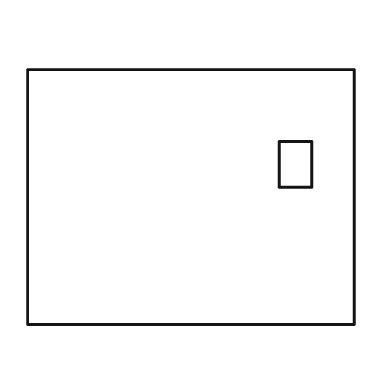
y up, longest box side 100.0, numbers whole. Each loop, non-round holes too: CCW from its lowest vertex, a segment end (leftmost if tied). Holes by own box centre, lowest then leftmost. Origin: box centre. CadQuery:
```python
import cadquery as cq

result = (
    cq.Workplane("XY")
    .moveTo(-50.0, -39.0)
    .lineTo(50.0, -39.0)
    .lineTo(50.0, 39.0)
    .lineTo(-50.0, 39.0)
    .close()
    .moveTo(27.0, 3.0)
    .lineTo(37.0, 3.0)
    .lineTo(37.0, 17.0)
    .lineTo(27.0, 17.0)
    .close()
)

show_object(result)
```